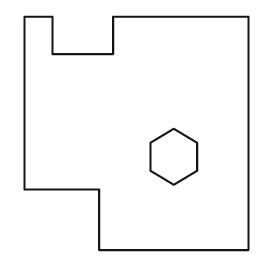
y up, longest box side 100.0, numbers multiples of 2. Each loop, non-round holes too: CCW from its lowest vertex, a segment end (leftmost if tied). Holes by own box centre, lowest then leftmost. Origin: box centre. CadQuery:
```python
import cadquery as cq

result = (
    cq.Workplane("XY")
    .moveTo(-16.0, -50.0)
    .lineTo(48.0, -50.0)
    .lineTo(48.0, 50.0)
    .lineTo(-10.0, 50.0)
    .lineTo(-10.0, 34.0)
    .lineTo(-36.0, 34.0)
    .lineTo(-36.0, 50.0)
    .lineTo(-48.0, 50.0)
    .lineTo(-48.0, -24.0)
    .lineTo(-16.0, -24.0)
    .close()
    .moveTo(16.0, -22.0)
    .lineTo(26.0, -16.0)
    .lineTo(26.0, -4.0)
    .lineTo(16.0, 2.0)
    .lineTo(6.0, -4.0)
    .lineTo(6.0, -16.0)
    .close()
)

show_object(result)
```